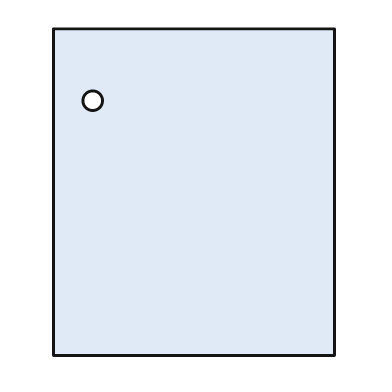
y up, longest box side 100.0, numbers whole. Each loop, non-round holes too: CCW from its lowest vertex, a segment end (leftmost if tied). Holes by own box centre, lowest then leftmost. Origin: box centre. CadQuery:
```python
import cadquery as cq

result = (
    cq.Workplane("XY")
    .moveTo(-43.0, -50.0)
    .lineTo(43.0, -50.0)
    .lineTo(43.0, 50.0)
    .lineTo(-43.0, 50.0)
    .close()
    .moveTo(-31.0, 28.0)
    .circle(3.0)
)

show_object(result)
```